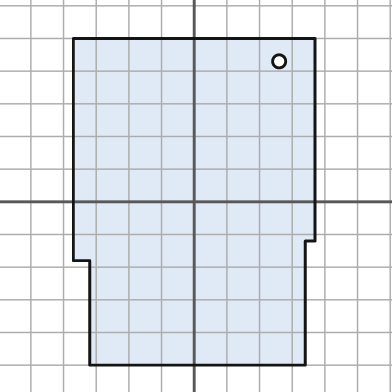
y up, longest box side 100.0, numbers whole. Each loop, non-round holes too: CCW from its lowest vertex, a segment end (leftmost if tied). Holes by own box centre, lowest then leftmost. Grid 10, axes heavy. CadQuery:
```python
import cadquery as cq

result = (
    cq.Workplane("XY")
    .moveTo(-32.0, -50.0)
    .lineTo(34.0, -50.0)
    .lineTo(34.0, -12.0)
    .lineTo(37.0, -12.0)
    .lineTo(37.0, 50.0)
    .lineTo(-37.0, 50.0)
    .lineTo(-37.0, -18.0)
    .lineTo(-32.0, -18.0)
    .close()
    .moveTo(26.0, 43.0)
    .circle(2.0)
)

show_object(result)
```